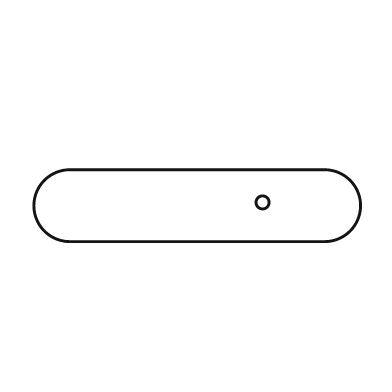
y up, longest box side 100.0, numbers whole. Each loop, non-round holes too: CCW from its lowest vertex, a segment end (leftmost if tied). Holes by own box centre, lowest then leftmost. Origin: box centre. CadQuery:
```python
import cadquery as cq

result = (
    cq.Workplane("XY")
    .moveTo(-39.0, -11.0)
    .lineTo(39.0, -11.0)
    .threePointArc((50.0, 0.0), (39.0, 11.0))
    .lineTo(-39.0, 11.0)
    .threePointArc((-50.0, 0.0), (-39.0, -11.0))
    .close()
    .moveTo(20.0, 1.0)
    .circle(2.0)
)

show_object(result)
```